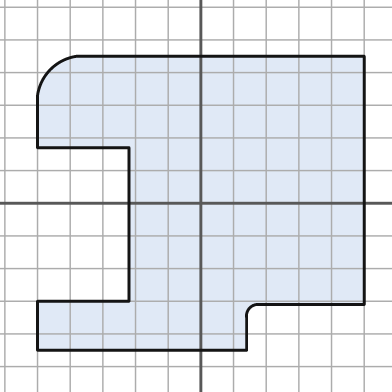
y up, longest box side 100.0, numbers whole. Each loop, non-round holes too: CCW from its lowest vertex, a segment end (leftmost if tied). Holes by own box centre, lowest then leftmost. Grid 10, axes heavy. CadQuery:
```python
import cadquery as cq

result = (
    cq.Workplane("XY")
    .moveTo(-50.0, -45.0)
    .lineTo(14.0, -45.0)
    .lineTo(14.0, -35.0)
    .threePointArc((15.0, -32.0), (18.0, -31.0))
    .lineTo(50.0, -31.0)
    .lineTo(50.0, 45.0)
    .lineTo(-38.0, 45.0)
    .threePointArc((-46.0, 41.0), (-50.0, 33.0))
    .lineTo(-50.0, 17.0)
    .lineTo(-22.0, 17.0)
    .lineTo(-22.0, -30.0)
    .lineTo(-50.0, -30.0)
    .close()
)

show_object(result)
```